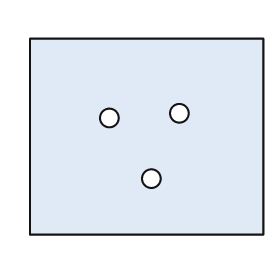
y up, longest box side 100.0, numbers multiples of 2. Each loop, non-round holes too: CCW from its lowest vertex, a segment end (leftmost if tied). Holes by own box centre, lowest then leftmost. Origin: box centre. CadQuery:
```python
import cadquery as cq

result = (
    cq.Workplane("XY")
    .moveTo(-50.0, -42.0)
    .lineTo(50.0, -42.0)
    .lineTo(50.0, 42.0)
    .lineTo(-50.0, 42.0)
    .close()
    .moveTo(2.0, -18.0)
    .circle(4.0)
    .moveTo(-16.0, 8.0)
    .circle(4.0)
    .moveTo(14.0, 10.0)
    .circle(4.0)
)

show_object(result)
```